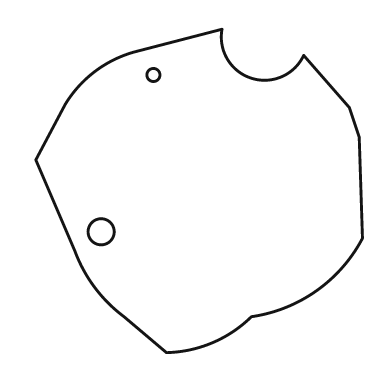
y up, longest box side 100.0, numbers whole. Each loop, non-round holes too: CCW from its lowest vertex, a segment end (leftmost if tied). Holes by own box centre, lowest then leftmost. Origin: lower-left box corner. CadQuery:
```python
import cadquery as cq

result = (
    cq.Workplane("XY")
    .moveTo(40.0, 0.0)
    .threePointArc((54.0, 3.0), (66.0, 11.0))
    .threePointArc((86.0, 19.0), (100.0, 35.0))
    .lineTo(99.0, 66.0)
    .lineTo(96.0, 75.0)
    .lineTo(82.0, 91.0)
    .threePointArc((66.0, 84.0), (57.0, 99.0))
    .lineTo(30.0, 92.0)
    .threePointArc((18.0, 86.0), (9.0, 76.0))
    .lineTo(0.0, 59.0)
    .lineTo(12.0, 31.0)
    .threePointArc((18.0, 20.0), (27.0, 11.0))
    .close()
    .moveTo(20.0, 37.0)
    .circle(4.0)
    .moveTo(36.0, 85.0)
    .circle(2.0)
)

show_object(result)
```